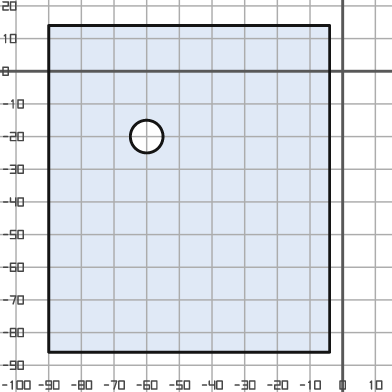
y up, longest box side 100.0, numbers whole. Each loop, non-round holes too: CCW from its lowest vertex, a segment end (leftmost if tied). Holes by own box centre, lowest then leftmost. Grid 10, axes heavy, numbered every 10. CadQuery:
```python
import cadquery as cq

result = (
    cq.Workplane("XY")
    .moveTo(-90.0, -86.0)
    .lineTo(-4.0, -86.0)
    .lineTo(-4.0, 14.0)
    .lineTo(-90.0, 14.0)
    .close()
    .moveTo(-60.0, -20.0)
    .circle(5.0)
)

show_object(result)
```